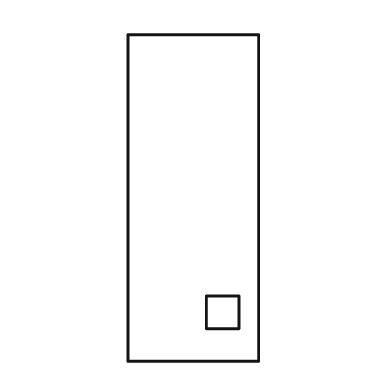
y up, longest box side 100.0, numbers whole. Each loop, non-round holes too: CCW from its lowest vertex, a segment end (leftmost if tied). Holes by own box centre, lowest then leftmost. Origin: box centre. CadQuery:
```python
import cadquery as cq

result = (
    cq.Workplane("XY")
    .moveTo(-20.0, -50.0)
    .lineTo(20.0, -50.0)
    .lineTo(20.0, 50.0)
    .lineTo(-20.0, 50.0)
    .close()
    .moveTo(4.0, -40.0)
    .lineTo(14.0, -40.0)
    .lineTo(14.0, -30.0)
    .lineTo(4.0, -30.0)
    .close()
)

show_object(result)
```